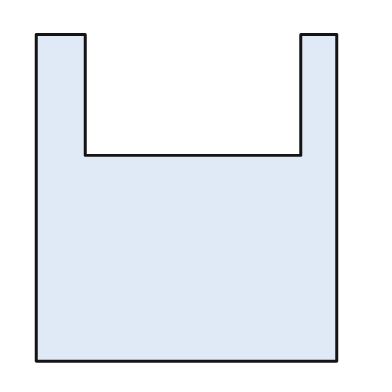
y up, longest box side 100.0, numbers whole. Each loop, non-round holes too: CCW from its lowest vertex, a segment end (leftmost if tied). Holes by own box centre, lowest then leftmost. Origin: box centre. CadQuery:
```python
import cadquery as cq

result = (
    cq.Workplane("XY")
    .moveTo(-46.0, -50.0)
    .lineTo(46.0, -50.0)
    .lineTo(46.0, 50.0)
    .lineTo(35.0, 50.0)
    .lineTo(35.0, 13.0)
    .lineTo(-31.0, 13.0)
    .lineTo(-31.0, 50.0)
    .lineTo(-46.0, 50.0)
    .close()
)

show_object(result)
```